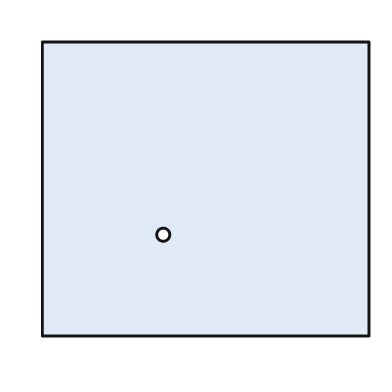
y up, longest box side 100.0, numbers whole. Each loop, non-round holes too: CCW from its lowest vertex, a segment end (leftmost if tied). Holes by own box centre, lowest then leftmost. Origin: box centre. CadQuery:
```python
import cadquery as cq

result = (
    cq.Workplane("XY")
    .moveTo(-50.0, -45.0)
    .lineTo(50.0, -45.0)
    .lineTo(50.0, 45.0)
    .lineTo(-50.0, 45.0)
    .close()
    .moveTo(-13.0, -14.0)
    .circle(2.0)
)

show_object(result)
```